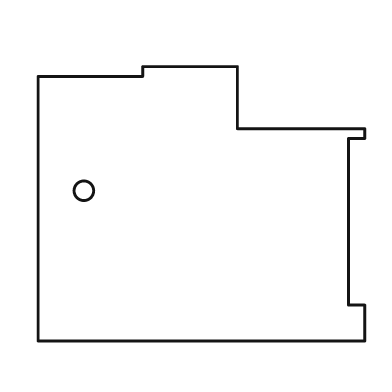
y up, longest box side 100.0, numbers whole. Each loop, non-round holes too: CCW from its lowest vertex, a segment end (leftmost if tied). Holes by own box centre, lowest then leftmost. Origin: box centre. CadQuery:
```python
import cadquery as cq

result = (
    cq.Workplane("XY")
    .moveTo(-50.0, -42.0)
    .lineTo(50.0, -42.0)
    .lineTo(50.0, -31.0)
    .lineTo(45.0, -31.0)
    .lineTo(45.0, 20.0)
    .lineTo(50.0, 20.0)
    .lineTo(50.0, 23.0)
    .lineTo(11.0, 23.0)
    .lineTo(11.0, 42.0)
    .lineTo(-18.0, 42.0)
    .lineTo(-18.0, 39.0)
    .lineTo(-50.0, 39.0)
    .close()
    .moveTo(-36.0, 4.0)
    .circle(3.0)
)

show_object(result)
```